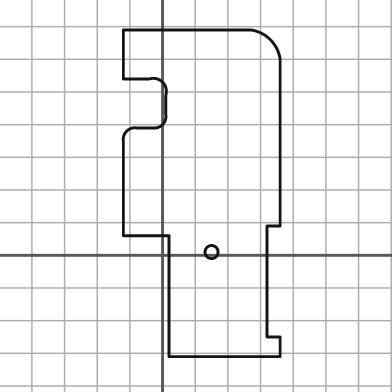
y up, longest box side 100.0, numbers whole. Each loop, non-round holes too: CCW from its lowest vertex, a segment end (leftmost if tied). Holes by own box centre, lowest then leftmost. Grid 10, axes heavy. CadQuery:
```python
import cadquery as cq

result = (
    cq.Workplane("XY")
    .moveTo(2.0, -31.0)
    .lineTo(36.0, -31.0)
    .lineTo(36.0, -25.0)
    .lineTo(32.0, -25.0)
    .lineTo(32.0, 9.0)
    .lineTo(36.0, 9.0)
    .lineTo(36.0, 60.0)
    .threePointArc((33.0, 66.0), (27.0, 69.0))
    .lineTo(-12.0, 69.0)
    .lineTo(-12.0, 54.0)
    .lineTo(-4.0, 54.0)
    .threePointArc((0.0, 53.0), (1.0, 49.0))
    .lineTo(1.0, 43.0)
    .threePointArc((0.0, 40.0), (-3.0, 39.0))
    .lineTo(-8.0, 39.0)
    .threePointArc((-11.0, 38.0), (-12.0, 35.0))
    .lineTo(-12.0, 6.0)
    .lineTo(2.0, 6.0)
    .close()
    .moveTo(15.0, 1.0)
    .circle(2.0)
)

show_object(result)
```